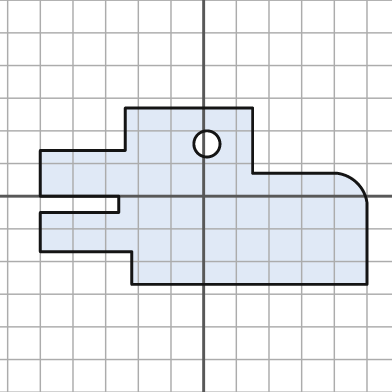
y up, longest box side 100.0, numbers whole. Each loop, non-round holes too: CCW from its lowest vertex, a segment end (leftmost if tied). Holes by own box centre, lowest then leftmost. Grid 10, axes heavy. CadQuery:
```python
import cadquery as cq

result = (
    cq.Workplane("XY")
    .moveTo(-22.0, -27.0)
    .lineTo(50.0, -27.0)
    .lineTo(50.0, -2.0)
    .threePointArc((47.0, 4.0), (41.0, 7.0))
    .lineTo(15.0, 7.0)
    .lineTo(15.0, 27.0)
    .lineTo(-24.0, 27.0)
    .lineTo(-24.0, 14.0)
    .lineTo(-50.0, 14.0)
    .lineTo(-50.0, 0.0)
    .lineTo(-26.0, 0.0)
    .lineTo(-26.0, -5.0)
    .lineTo(-50.0, -5.0)
    .lineTo(-50.0, -17.0)
    .lineTo(-22.0, -17.0)
    .close()
    .moveTo(1.0, 16.0)
    .circle(4.0)
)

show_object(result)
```